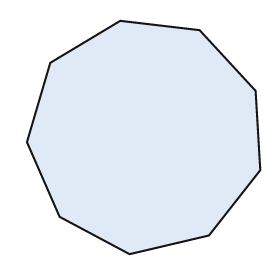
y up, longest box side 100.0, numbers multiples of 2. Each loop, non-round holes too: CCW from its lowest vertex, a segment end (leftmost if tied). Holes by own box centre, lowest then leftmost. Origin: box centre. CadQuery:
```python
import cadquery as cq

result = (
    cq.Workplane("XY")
    .moveTo(-6.0, -50.0)
    .lineTo(28.0, -42.0)
    .lineTo(50.0, -14.0)
    .lineTo(48.0, 20.0)
    .lineTo(24.0, 46.0)
    .lineTo(-10.0, 50.0)
    .lineTo(-40.0, 32.0)
    .lineTo(-50.0, -2.0)
    .lineTo(-36.0, -34.0)
    .close()
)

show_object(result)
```